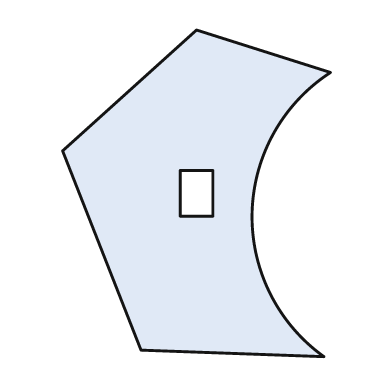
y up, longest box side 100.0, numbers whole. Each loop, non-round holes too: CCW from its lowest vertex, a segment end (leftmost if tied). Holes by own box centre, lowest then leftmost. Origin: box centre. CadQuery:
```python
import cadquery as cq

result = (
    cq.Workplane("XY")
    .moveTo(39.0, -50.0)
    .threePointArc((17.0, -6.0), (41.0, 37.0))
    .lineTo(0.0, 50.0)
    .lineTo(-41.0, 13.0)
    .lineTo(-17.0, -48.0)
    .close()
    .moveTo(-5.0, -7.0)
    .lineTo(5.0, -7.0)
    .lineTo(5.0, 7.0)
    .lineTo(-5.0, 7.0)
    .close()
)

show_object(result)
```